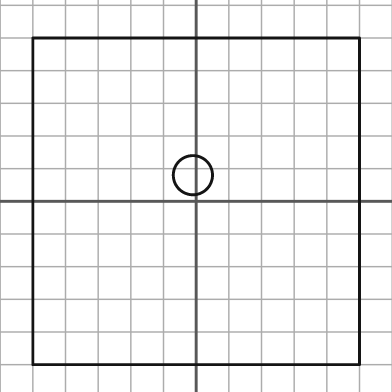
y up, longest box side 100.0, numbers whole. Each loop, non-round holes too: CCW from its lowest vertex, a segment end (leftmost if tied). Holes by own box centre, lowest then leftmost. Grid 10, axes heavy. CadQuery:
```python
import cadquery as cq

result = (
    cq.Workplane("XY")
    .moveTo(-50.0, -50.0)
    .lineTo(50.0, -50.0)
    .lineTo(50.0, 50.0)
    .lineTo(-50.0, 50.0)
    .close()
    .moveTo(-1.0, 8.0)
    .circle(6.0)
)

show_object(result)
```